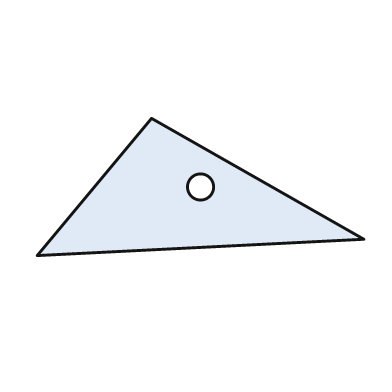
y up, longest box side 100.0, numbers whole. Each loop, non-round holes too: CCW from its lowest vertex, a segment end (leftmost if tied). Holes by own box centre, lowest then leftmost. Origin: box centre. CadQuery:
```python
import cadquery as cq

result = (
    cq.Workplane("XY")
    .moveTo(-50.0, -21.0)
    .lineTo(50.0, -16.0)
    .lineTo(-15.0, 21.0)
    .close()
    .moveTo(0.0, 0.0)
    .circle(4.0)
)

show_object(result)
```